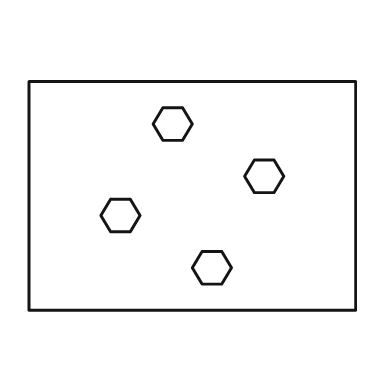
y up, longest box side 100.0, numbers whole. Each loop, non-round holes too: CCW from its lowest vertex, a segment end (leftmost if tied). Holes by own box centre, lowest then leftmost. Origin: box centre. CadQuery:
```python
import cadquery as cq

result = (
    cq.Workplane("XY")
    .moveTo(-50.0, -35.0)
    .lineTo(50.0, -35.0)
    .lineTo(50.0, 35.0)
    .lineTo(-50.0, 35.0)
    .close()
    .moveTo(3.0, -27.0)
    .lineTo(9.0, -27.0)
    .lineTo(12.0, -22.0)
    .lineTo(9.0, -17.0)
    .lineTo(3.0, -17.0)
    .lineTo(0.0, -22.0)
    .close()
    .moveTo(-25.0, -11.0)
    .lineTo(-19.0, -11.0)
    .lineTo(-16.0, -6.0)
    .lineTo(-19.0, -1.0)
    .lineTo(-25.0, -1.0)
    .lineTo(-28.0, -6.0)
    .close()
    .moveTo(19.0, 1.0)
    .lineTo(25.0, 1.0)
    .lineTo(28.0, 6.0)
    .lineTo(25.0, 11.0)
    .lineTo(19.0, 11.0)
    .lineTo(16.0, 6.0)
    .close()
    .moveTo(-9.0, 17.0)
    .lineTo(-3.0, 17.0)
    .lineTo(0.0, 22.0)
    .lineTo(-3.0, 27.0)
    .lineTo(-9.0, 27.0)
    .lineTo(-12.0, 22.0)
    .close()
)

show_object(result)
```